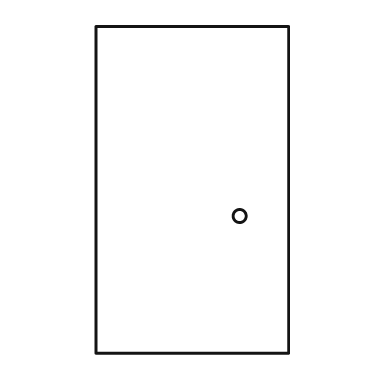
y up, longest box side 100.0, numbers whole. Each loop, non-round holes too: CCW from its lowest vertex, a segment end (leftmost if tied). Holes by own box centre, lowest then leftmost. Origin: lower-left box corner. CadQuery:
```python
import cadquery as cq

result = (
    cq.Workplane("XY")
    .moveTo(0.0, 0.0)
    .lineTo(59.0, 0.0)
    .lineTo(59.0, 100.0)
    .lineTo(0.0, 100.0)
    .close()
    .moveTo(44.0, 42.0)
    .circle(2.0)
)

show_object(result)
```